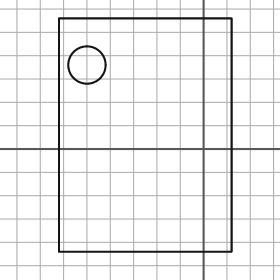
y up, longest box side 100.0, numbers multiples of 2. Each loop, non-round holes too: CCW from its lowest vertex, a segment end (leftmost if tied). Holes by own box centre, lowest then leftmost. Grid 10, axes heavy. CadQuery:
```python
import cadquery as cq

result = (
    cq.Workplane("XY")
    .moveTo(-62.0, -44.0)
    .lineTo(12.0, -44.0)
    .lineTo(12.0, 56.0)
    .lineTo(-62.0, 56.0)
    .close()
    .moveTo(-50.0, 36.0)
    .circle(8.0)
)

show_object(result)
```